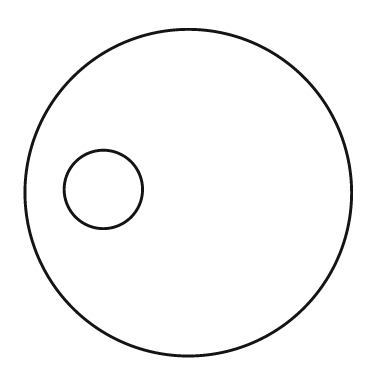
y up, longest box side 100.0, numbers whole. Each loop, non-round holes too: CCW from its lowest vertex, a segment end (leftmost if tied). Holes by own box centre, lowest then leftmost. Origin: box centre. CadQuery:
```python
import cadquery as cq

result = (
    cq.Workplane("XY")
    .moveTo(0.0, 0.0)
    .circle(50.0)
    .moveTo(-26.0, 1.0)
    .circle(12.0)
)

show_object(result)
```